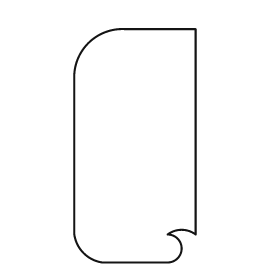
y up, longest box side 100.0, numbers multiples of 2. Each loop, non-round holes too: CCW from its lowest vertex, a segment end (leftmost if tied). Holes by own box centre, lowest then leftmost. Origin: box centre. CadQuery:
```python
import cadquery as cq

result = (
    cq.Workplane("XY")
    .moveTo(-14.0, -50.0)
    .lineTo(14.0, -50.0)
    .threePointArc((20.0, -44.0), (14.0, -38.0))
    .threePointArc((20.0, -36.0), (26.0, -38.0))
    .lineTo(26.0, 50.0)
    .lineTo(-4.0, 50.0)
    .threePointArc((-20.0, 44.0), (-26.0, 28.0))
    .lineTo(-26.0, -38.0)
    .threePointArc((-22.0, -46.0), (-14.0, -50.0))
    .close()
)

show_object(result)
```